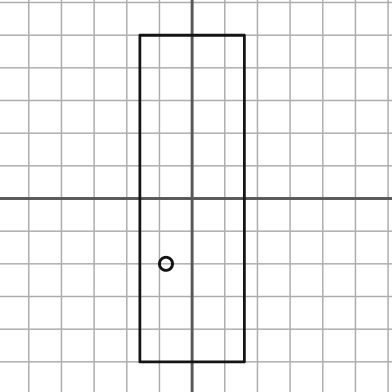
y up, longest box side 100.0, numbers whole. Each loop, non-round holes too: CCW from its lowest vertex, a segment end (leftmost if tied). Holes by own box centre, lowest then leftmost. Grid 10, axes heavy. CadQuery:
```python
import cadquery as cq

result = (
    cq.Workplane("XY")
    .moveTo(-16.0, -50.0)
    .lineTo(16.0, -50.0)
    .lineTo(16.0, 50.0)
    .lineTo(-16.0, 50.0)
    .close()
    .moveTo(-8.0, -20.0)
    .circle(2.0)
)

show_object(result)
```